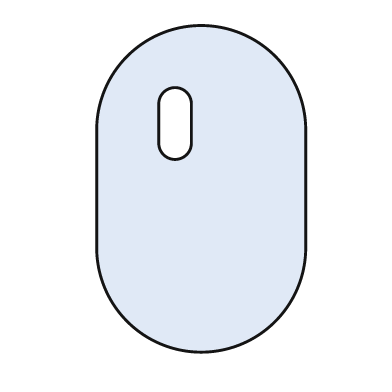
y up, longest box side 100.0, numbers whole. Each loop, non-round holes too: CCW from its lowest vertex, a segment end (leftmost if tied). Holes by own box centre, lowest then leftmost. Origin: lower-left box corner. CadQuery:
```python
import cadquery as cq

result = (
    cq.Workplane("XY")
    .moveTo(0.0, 32.0)
    .threePointArc((32.0, 0.0), (64.0, 32.0))
    .lineTo(64.0, 68.0)
    .threePointArc((32.0, 100.0), (0.0, 68.0))
    .close()
    .moveTo(19.0, 64.0)
    .threePointArc((24.0, 59.0), (29.0, 64.0))
    .lineTo(29.0, 76.0)
    .threePointArc((24.0, 81.0), (19.0, 76.0))
    .close()
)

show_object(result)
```